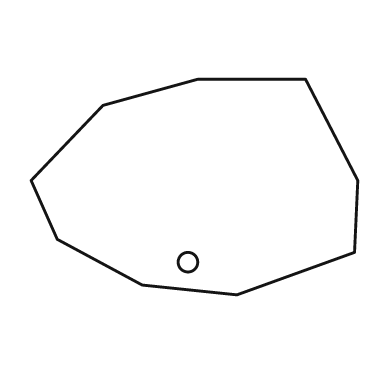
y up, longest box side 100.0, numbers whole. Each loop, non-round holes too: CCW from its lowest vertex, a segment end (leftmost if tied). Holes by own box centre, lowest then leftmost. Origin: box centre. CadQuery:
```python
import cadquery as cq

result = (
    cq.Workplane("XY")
    .moveTo(13.0, -33.0)
    .lineTo(49.0, -20.0)
    .lineTo(50.0, 2.0)
    .lineTo(34.0, 33.0)
    .lineTo(1.0, 33.0)
    .lineTo(-28.0, 25.0)
    .lineTo(-50.0, 2.0)
    .lineTo(-42.0, -16.0)
    .lineTo(-16.0, -30.0)
    .close()
    .moveTo(-2.0, -23.0)
    .circle(3.0)
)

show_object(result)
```